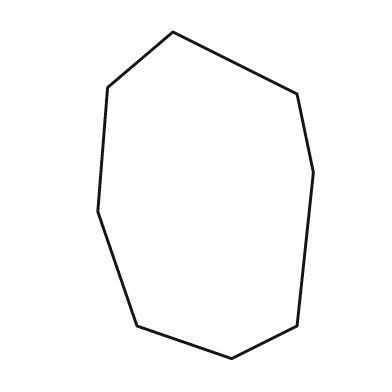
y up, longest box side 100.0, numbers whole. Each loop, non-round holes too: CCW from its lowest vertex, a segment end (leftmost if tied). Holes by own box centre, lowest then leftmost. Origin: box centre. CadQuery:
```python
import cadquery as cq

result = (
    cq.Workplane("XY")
    .moveTo(8.0, -50.0)
    .lineTo(28.0, -40.0)
    .lineTo(33.0, 7.0)
    .lineTo(28.0, 31.0)
    .lineTo(-10.0, 50.0)
    .lineTo(-30.0, 33.0)
    .lineTo(-33.0, -5.0)
    .lineTo(-21.0, -40.0)
    .close()
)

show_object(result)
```